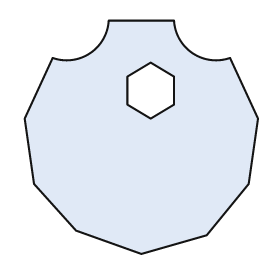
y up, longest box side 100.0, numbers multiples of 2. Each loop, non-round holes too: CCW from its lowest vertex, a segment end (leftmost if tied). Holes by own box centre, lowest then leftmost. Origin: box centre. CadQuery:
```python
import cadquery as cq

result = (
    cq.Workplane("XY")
    .moveTo(0.0, -50.0)
    .lineTo(28.0, -42.0)
    .lineTo(46.0, -20.0)
    .lineTo(50.0, 8.0)
    .lineTo(38.0, 34.0)
    .threePointArc((22.0, 36.0), (14.0, 50.0))
    .lineTo(-14.0, 50.0)
    .threePointArc((-22.0, 36.0), (-38.0, 34.0))
    .lineTo(-50.0, 8.0)
    .lineTo(-46.0, -20.0)
    .lineTo(-28.0, -40.0)
    .close()
    .moveTo(4.0, 8.0)
    .lineTo(14.0, 14.0)
    .lineTo(14.0, 26.0)
    .lineTo(4.0, 32.0)
    .lineTo(-6.0, 26.0)
    .lineTo(-6.0, 14.0)
    .close()
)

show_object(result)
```